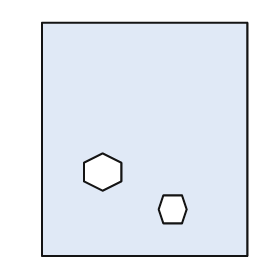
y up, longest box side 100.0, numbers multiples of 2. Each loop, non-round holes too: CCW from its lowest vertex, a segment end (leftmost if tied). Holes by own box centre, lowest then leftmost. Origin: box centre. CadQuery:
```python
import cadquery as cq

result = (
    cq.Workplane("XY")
    .moveTo(-44.0, -50.0)
    .lineTo(44.0, -50.0)
    .lineTo(44.0, 50.0)
    .lineTo(-44.0, 50.0)
    .close()
    .moveTo(8.0, -36.0)
    .lineTo(16.0, -36.0)
    .lineTo(18.0, -30.0)
    .lineTo(16.0, -24.0)
    .lineTo(8.0, -24.0)
    .lineTo(6.0, -30.0)
    .close()
    .moveTo(-18.0, -22.0)
    .lineTo(-10.0, -18.0)
    .lineTo(-10.0, -10.0)
    .lineTo(-18.0, -6.0)
    .lineTo(-26.0, -10.0)
    .lineTo(-26.0, -18.0)
    .close()
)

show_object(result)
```